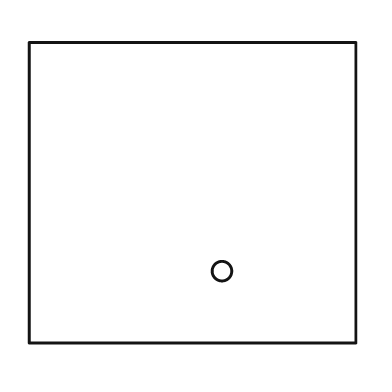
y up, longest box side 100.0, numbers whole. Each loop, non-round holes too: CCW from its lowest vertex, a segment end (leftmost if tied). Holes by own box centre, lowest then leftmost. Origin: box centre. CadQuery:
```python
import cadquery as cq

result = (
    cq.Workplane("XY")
    .moveTo(-50.0, -46.0)
    .lineTo(50.0, -46.0)
    .lineTo(50.0, 46.0)
    .lineTo(-50.0, 46.0)
    .close()
    .moveTo(9.0, -24.0)
    .circle(3.0)
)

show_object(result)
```